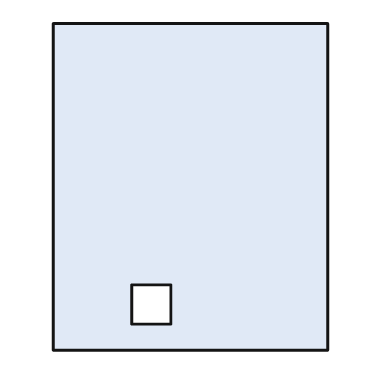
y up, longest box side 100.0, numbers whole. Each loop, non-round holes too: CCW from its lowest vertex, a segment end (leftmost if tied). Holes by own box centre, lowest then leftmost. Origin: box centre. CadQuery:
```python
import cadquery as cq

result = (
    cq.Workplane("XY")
    .moveTo(-42.0, -50.0)
    .lineTo(42.0, -50.0)
    .lineTo(42.0, 50.0)
    .lineTo(-42.0, 50.0)
    .close()
    .moveTo(-18.0, -42.0)
    .lineTo(-6.0, -42.0)
    .lineTo(-6.0, -30.0)
    .lineTo(-18.0, -30.0)
    .close()
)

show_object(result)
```